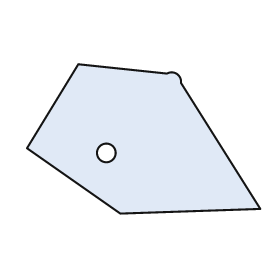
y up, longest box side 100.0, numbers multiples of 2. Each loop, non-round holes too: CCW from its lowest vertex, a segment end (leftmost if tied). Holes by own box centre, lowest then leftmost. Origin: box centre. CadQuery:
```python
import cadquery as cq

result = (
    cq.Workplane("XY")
    .moveTo(-10.0, -32.0)
    .lineTo(50.0, -30.0)
    .lineTo(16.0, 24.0)
    .threePointArc((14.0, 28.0), (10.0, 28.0))
    .lineTo(-28.0, 32.0)
    .lineTo(-50.0, -4.0)
    .close()
    .moveTo(-16.0, -6.0)
    .circle(4.0)
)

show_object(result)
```